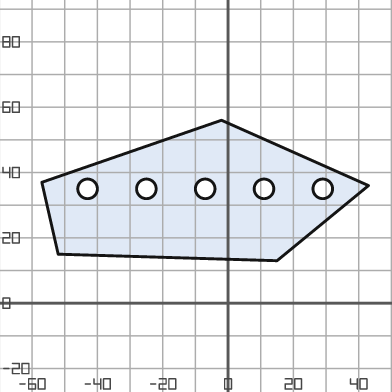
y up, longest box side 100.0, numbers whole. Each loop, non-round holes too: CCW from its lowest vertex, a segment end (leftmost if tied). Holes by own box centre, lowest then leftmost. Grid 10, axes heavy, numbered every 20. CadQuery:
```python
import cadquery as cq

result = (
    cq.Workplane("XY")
    .moveTo(15.0, 13.0)
    .lineTo(43.0, 36.0)
    .lineTo(-2.0, 56.0)
    .lineTo(-57.0, 37.0)
    .lineTo(-52.0, 15.0)
    .close()
    .moveTo(-43.0, 35.0)
    .circle(3.0)
    .moveTo(-25.0, 35.0)
    .circle(3.0)
    .moveTo(-7.0, 35.0)
    .circle(3.0)
    .moveTo(11.0, 35.0)
    .circle(3.0)
    .moveTo(29.0, 35.0)
    .circle(3.0)
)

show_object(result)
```